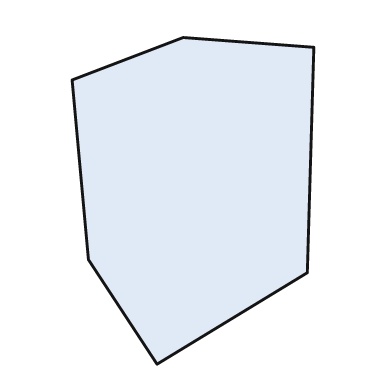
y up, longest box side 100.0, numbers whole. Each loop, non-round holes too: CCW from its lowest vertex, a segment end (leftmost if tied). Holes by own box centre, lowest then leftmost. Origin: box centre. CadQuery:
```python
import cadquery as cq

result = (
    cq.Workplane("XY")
    .moveTo(-11.0, -50.0)
    .lineTo(35.0, -22.0)
    .lineTo(37.0, 47.0)
    .lineTo(-3.0, 50.0)
    .lineTo(-37.0, 37.0)
    .lineTo(-32.0, -18.0)
    .close()
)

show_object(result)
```